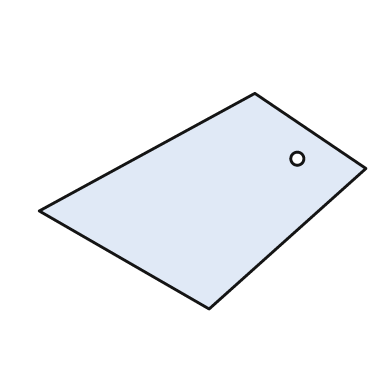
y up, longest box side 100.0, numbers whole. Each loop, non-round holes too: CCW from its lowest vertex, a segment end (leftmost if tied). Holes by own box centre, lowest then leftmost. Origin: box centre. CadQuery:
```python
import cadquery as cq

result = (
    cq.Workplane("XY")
    .moveTo(2.0, -33.0)
    .lineTo(50.0, 10.0)
    .lineTo(16.0, 33.0)
    .lineTo(-50.0, -3.0)
    .close()
    .moveTo(29.0, 13.0)
    .circle(2.0)
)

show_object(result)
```